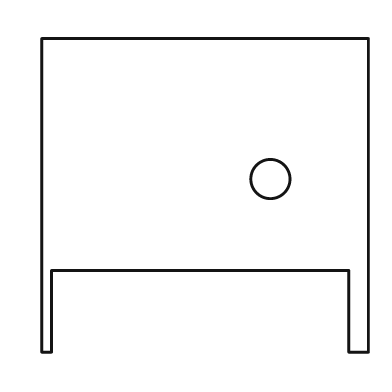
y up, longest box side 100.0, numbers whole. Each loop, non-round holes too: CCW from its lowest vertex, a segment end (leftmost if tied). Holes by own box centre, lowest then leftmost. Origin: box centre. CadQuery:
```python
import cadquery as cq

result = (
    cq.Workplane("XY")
    .moveTo(-50.0, -48.0)
    .lineTo(-47.0, -48.0)
    .lineTo(-47.0, -23.0)
    .lineTo(44.0, -23.0)
    .lineTo(44.0, -48.0)
    .lineTo(50.0, -48.0)
    .lineTo(50.0, 48.0)
    .lineTo(-50.0, 48.0)
    .close()
    .moveTo(20.0, 5.0)
    .circle(6.0)
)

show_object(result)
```